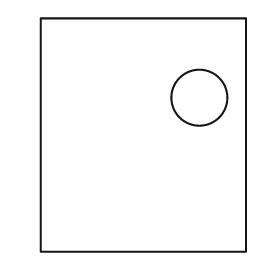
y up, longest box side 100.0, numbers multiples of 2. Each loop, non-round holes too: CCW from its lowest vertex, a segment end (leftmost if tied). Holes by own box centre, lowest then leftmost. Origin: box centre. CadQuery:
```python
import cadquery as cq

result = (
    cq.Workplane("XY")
    .moveTo(-44.0, -50.0)
    .lineTo(44.0, -50.0)
    .lineTo(44.0, 50.0)
    .lineTo(-44.0, 50.0)
    .close()
    .moveTo(24.0, 16.0)
    .circle(12.0)
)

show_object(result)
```